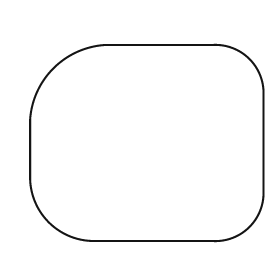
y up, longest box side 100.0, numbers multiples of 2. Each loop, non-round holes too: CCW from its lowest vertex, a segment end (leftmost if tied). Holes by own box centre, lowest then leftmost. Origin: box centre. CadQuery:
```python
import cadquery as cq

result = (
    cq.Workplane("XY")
    .moveTo(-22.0, -42.0)
    .lineTo(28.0, -42.0)
    .threePointArc((44.0, -36.0), (50.0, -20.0))
    .lineTo(50.0, 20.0)
    .threePointArc((44.0, 36.0), (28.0, 42.0))
    .lineTo(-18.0, 42.0)
    .threePointArc((-40.0, 32.0), (-50.0, 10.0))
    .lineTo(-50.0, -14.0)
    .threePointArc((-42.0, -34.0), (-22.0, -42.0))
    .close()
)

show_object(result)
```